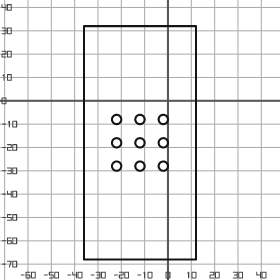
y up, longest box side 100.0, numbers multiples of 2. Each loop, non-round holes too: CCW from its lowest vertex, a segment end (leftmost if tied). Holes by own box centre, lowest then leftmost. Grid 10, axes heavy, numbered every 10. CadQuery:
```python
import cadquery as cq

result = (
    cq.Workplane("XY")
    .moveTo(-36.0, -68.0)
    .lineTo(12.0, -68.0)
    .lineTo(12.0, 32.0)
    .lineTo(-36.0, 32.0)
    .close()
    .moveTo(-22.0, -28.0)
    .circle(2.0)
    .moveTo(-12.0, -28.0)
    .circle(2.0)
    .moveTo(-2.0, -28.0)
    .circle(2.0)
    .moveTo(-22.0, -18.0)
    .circle(2.0)
    .moveTo(-12.0, -18.0)
    .circle(2.0)
    .moveTo(-2.0, -18.0)
    .circle(2.0)
    .moveTo(-22.0, -8.0)
    .circle(2.0)
    .moveTo(-12.0, -8.0)
    .circle(2.0)
    .moveTo(-2.0, -8.0)
    .circle(2.0)
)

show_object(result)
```